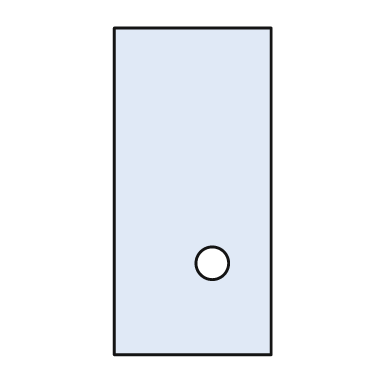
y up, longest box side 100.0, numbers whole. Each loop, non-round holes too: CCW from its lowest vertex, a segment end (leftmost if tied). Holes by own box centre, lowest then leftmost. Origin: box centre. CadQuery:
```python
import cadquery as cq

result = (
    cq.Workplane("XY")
    .moveTo(-24.0, -50.0)
    .lineTo(24.0, -50.0)
    .lineTo(24.0, 50.0)
    .lineTo(-24.0, 50.0)
    .close()
    .moveTo(6.0, -22.0)
    .circle(5.0)
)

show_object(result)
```